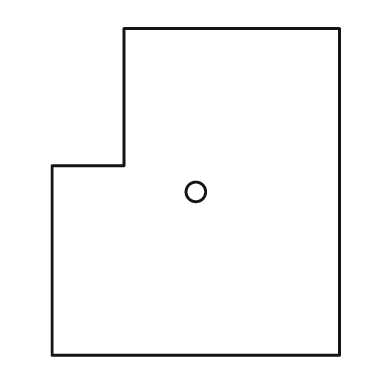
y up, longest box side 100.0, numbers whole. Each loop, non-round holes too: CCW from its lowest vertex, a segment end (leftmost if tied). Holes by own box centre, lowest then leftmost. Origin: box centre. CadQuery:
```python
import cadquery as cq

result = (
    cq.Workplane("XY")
    .moveTo(-44.0, -50.0)
    .lineTo(44.0, -50.0)
    .lineTo(44.0, 50.0)
    .lineTo(-22.0, 50.0)
    .lineTo(-22.0, 8.0)
    .lineTo(-44.0, 8.0)
    .close()
    .moveTo(0.0, 0.0)
    .circle(3.0)
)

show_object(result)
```